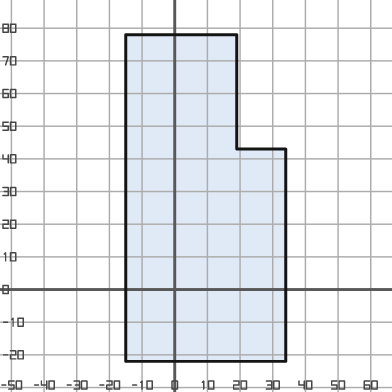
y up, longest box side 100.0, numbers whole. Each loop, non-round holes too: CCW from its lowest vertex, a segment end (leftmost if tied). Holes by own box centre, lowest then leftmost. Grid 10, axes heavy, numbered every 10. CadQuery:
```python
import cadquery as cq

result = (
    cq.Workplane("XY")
    .moveTo(-15.0, -22.0)
    .lineTo(34.0, -22.0)
    .lineTo(34.0, 43.0)
    .lineTo(19.0, 43.0)
    .lineTo(19.0, 78.0)
    .lineTo(-15.0, 78.0)
    .close()
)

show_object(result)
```